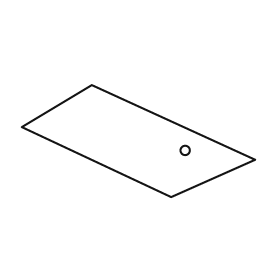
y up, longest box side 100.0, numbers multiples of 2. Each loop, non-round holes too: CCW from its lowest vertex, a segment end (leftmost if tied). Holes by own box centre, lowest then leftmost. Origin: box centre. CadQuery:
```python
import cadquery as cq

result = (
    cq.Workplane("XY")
    .moveTo(14.0, -24.0)
    .lineTo(50.0, -8.0)
    .lineTo(-20.0, 24.0)
    .lineTo(-50.0, 6.0)
    .close()
    .moveTo(20.0, -4.0)
    .circle(2.0)
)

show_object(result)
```